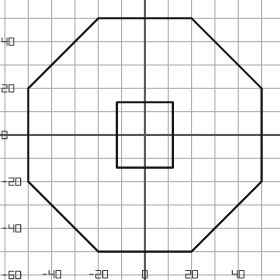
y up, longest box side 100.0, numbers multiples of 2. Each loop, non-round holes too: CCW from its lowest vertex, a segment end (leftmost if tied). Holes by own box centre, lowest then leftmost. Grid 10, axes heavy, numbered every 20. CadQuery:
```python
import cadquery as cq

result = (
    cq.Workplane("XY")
    .moveTo(-20.0, -50.0)
    .lineTo(20.0, -50.0)
    .lineTo(50.0, -20.0)
    .lineTo(50.0, 20.0)
    .lineTo(20.0, 50.0)
    .lineTo(-20.0, 50.0)
    .lineTo(-50.0, 20.0)
    .lineTo(-50.0, -20.0)
    .close()
    .moveTo(-12.0, -14.0)
    .lineTo(12.0, -14.0)
    .lineTo(12.0, 14.0)
    .lineTo(-12.0, 14.0)
    .close()
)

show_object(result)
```